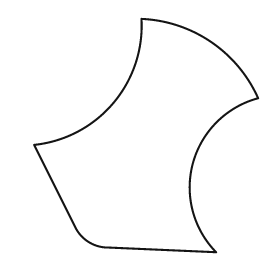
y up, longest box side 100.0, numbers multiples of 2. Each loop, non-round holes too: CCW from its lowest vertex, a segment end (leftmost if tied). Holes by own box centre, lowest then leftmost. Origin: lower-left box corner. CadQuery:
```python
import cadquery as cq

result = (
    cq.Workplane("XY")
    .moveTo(78.0, 0.0)
    .threePointArc((68.0, 38.0), (96.0, 66.0))
    .threePointArc((76.0, 90.0), (46.0, 100.0))
    .threePointArc((34.0, 64.0), (0.0, 46.0))
    .lineTo(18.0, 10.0)
    .threePointArc((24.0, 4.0), (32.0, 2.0))
    .close()
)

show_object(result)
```